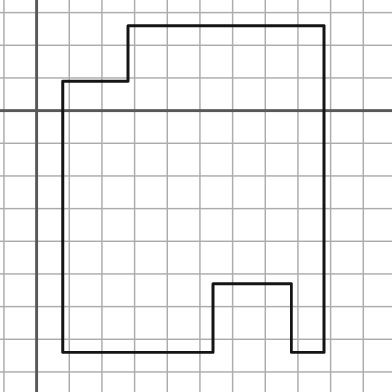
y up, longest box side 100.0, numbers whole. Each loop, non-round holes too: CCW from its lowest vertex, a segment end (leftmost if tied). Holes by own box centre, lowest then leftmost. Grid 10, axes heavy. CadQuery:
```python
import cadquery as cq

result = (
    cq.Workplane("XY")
    .moveTo(8.0, -74.0)
    .lineTo(54.0, -74.0)
    .lineTo(54.0, -53.0)
    .lineTo(78.0, -53.0)
    .lineTo(78.0, -74.0)
    .lineTo(88.0, -74.0)
    .lineTo(88.0, 26.0)
    .lineTo(28.0, 26.0)
    .lineTo(28.0, 9.0)
    .lineTo(8.0, 9.0)
    .close()
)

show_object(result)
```